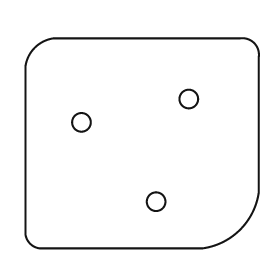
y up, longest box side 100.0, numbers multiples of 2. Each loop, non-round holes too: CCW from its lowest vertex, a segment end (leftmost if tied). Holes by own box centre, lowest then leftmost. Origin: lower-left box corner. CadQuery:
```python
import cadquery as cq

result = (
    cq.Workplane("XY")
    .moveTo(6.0, 0.0)
    .lineTo(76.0, 0.0)
    .threePointArc((92.0, 8.0), (100.0, 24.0))
    .lineTo(100.0, 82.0)
    .threePointArc((98.0, 88.0), (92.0, 90.0))
    .lineTo(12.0, 90.0)
    .threePointArc((4.0, 86.0), (0.0, 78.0))
    .lineTo(0.0, 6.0)
    .threePointArc((2.0, 2.0), (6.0, 0.0))
    .close()
    .moveTo(56.0, 20.0)
    .circle(4.0)
    .moveTo(24.0, 54.0)
    .circle(4.0)
    .moveTo(70.0, 64.0)
    .circle(4.0)
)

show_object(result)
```